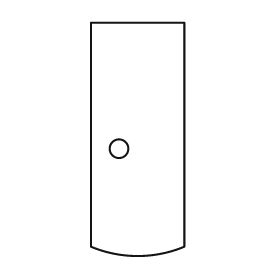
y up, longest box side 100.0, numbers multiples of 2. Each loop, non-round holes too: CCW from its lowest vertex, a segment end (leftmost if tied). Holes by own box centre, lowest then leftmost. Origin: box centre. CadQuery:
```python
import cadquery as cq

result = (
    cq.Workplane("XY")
    .moveTo(-20.0, -46.0)
    .threePointArc((0.0, -50.0), (20.0, -46.0))
    .lineTo(20.0, 50.0)
    .lineTo(-20.0, 50.0)
    .close()
    .moveTo(-8.0, -4.0)
    .circle(4.0)
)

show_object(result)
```